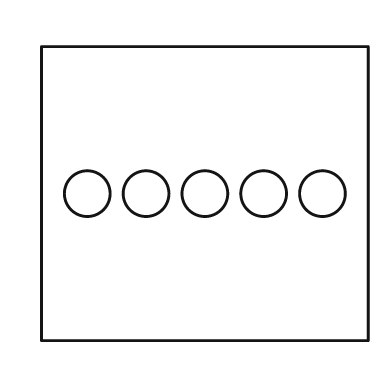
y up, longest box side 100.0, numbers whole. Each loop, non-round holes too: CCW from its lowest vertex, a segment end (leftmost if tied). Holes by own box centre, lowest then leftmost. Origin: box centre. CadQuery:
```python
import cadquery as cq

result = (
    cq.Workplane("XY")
    .moveTo(-50.0, -45.0)
    .lineTo(50.0, -45.0)
    .lineTo(50.0, 45.0)
    .lineTo(-50.0, 45.0)
    .close()
    .moveTo(-36.0, 0.0)
    .circle(7.0)
    .moveTo(-18.0, 0.0)
    .circle(7.0)
    .moveTo(0.0, 0.0)
    .circle(7.0)
    .moveTo(18.0, 0.0)
    .circle(7.0)
    .moveTo(36.0, 0.0)
    .circle(7.0)
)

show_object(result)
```